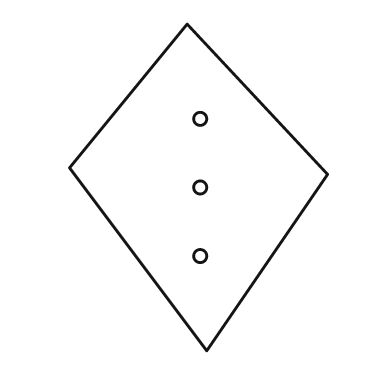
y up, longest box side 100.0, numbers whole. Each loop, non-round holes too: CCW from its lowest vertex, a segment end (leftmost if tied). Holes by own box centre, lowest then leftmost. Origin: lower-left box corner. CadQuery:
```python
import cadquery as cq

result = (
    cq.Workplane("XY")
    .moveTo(42.0, 0.0)
    .lineTo(79.0, 54.0)
    .lineTo(36.0, 100.0)
    .lineTo(0.0, 56.0)
    .close()
    .moveTo(40.0, 29.0)
    .circle(2.0)
    .moveTo(40.0, 50.0)
    .circle(2.0)
    .moveTo(40.0, 71.0)
    .circle(2.0)
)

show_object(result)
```